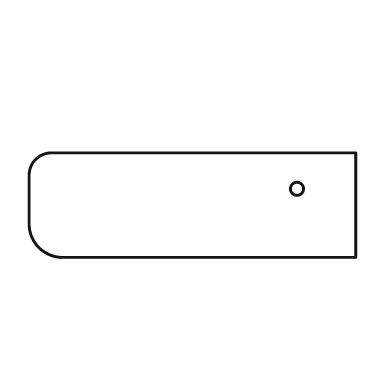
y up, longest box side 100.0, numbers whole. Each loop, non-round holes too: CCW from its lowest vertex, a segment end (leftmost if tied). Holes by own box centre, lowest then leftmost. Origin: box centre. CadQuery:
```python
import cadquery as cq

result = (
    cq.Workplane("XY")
    .moveTo(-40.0, -16.0)
    .lineTo(50.0, -16.0)
    .lineTo(50.0, 16.0)
    .lineTo(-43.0, 16.0)
    .threePointArc((-48.0, 14.0), (-50.0, 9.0))
    .lineTo(-50.0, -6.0)
    .threePointArc((-47.0, -13.0), (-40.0, -16.0))
    .close()
    .moveTo(32.0, 5.0)
    .circle(2.0)
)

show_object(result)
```